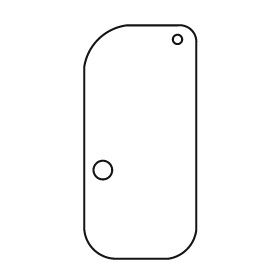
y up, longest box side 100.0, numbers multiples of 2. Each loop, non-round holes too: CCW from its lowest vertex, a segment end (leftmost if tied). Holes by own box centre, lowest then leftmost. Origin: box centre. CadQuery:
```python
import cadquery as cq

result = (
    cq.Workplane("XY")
    .moveTo(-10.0, -50.0)
    .lineTo(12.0, -50.0)
    .threePointArc((20.0, -46.0), (24.0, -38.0))
    .lineTo(24.0, 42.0)
    .threePointArc((22.0, 48.0), (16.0, 50.0))
    .lineTo(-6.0, 50.0)
    .threePointArc((-18.0, 44.0), (-24.0, 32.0))
    .lineTo(-24.0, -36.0)
    .threePointArc((-20.0, -46.0), (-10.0, -50.0))
    .close()
    .moveTo(-16.0, -12.0)
    .circle(4.0)
    .moveTo(16.0, 44.0)
    .circle(2.0)
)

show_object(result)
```